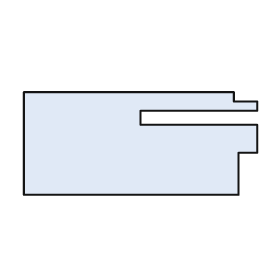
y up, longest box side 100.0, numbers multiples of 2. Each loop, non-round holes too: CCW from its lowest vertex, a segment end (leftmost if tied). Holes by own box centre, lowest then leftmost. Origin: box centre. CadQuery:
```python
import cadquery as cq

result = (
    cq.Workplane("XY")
    .moveTo(-50.0, -22.0)
    .lineTo(42.0, -22.0)
    .lineTo(42.0, -4.0)
    .lineTo(50.0, -4.0)
    .lineTo(50.0, 8.0)
    .lineTo(0.0, 8.0)
    .lineTo(0.0, 14.0)
    .lineTo(50.0, 14.0)
    .lineTo(50.0, 18.0)
    .lineTo(40.0, 18.0)
    .lineTo(40.0, 22.0)
    .lineTo(-50.0, 22.0)
    .close()
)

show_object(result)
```